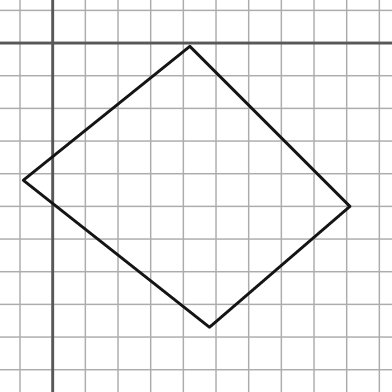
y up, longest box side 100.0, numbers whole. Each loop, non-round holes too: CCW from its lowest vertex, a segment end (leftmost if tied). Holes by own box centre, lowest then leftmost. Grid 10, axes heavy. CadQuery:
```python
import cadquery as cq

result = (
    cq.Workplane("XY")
    .moveTo(48.0, -87.0)
    .lineTo(91.0, -50.0)
    .lineTo(42.0, -1.0)
    .lineTo(-9.0, -42.0)
    .close()
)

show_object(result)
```